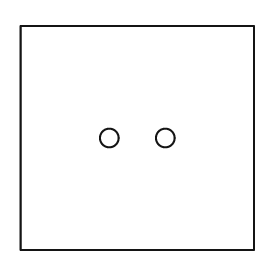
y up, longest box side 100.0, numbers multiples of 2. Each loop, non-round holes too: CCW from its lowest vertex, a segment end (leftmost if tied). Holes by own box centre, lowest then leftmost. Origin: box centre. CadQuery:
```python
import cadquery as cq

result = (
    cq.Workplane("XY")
    .moveTo(-50.0, -48.0)
    .lineTo(50.0, -48.0)
    .lineTo(50.0, 48.0)
    .lineTo(-50.0, 48.0)
    .close()
    .moveTo(-12.0, 0.0)
    .circle(4.0)
    .moveTo(12.0, 0.0)
    .circle(4.0)
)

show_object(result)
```